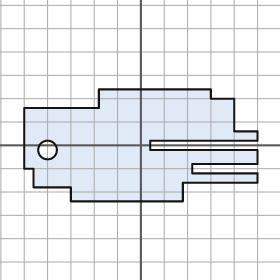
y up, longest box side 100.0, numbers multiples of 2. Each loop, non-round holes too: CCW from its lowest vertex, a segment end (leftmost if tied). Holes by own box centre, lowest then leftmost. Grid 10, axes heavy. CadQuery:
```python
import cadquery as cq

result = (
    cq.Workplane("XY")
    .moveTo(-30.0, -24.0)
    .lineTo(18.0, -24.0)
    .lineTo(18.0, -16.0)
    .lineTo(50.0, -16.0)
    .lineTo(50.0, -12.0)
    .lineTo(22.0, -12.0)
    .lineTo(22.0, -8.0)
    .lineTo(50.0, -8.0)
    .lineTo(50.0, -2.0)
    .lineTo(4.0, -2.0)
    .lineTo(4.0, 2.0)
    .lineTo(50.0, 2.0)
    .lineTo(50.0, 6.0)
    .lineTo(40.0, 6.0)
    .lineTo(40.0, 20.0)
    .lineTo(30.0, 20.0)
    .lineTo(30.0, 24.0)
    .lineTo(-18.0, 24.0)
    .lineTo(-18.0, 16.0)
    .lineTo(-50.0, 16.0)
    .lineTo(-50.0, -10.0)
    .lineTo(-46.0, -10.0)
    .lineTo(-46.0, -18.0)
    .lineTo(-30.0, -18.0)
    .close()
    .moveTo(-40.0, -2.0)
    .circle(4.0)
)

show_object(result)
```